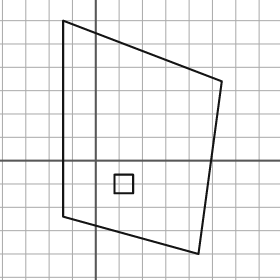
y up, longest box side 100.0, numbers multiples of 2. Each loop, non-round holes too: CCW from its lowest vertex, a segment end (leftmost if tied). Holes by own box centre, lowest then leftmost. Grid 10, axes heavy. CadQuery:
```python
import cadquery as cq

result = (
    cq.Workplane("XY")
    .moveTo(44.0, -40.0)
    .lineTo(54.0, 34.0)
    .lineTo(-14.0, 60.0)
    .lineTo(-14.0, -24.0)
    .close()
    .moveTo(8.0, -14.0)
    .lineTo(16.0, -14.0)
    .lineTo(16.0, -6.0)
    .lineTo(8.0, -6.0)
    .close()
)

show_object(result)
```